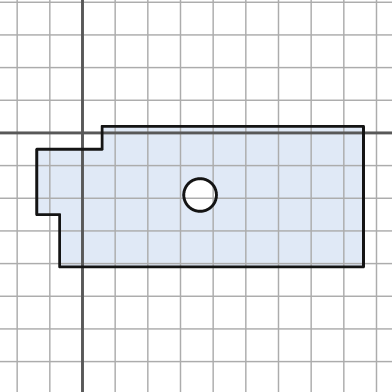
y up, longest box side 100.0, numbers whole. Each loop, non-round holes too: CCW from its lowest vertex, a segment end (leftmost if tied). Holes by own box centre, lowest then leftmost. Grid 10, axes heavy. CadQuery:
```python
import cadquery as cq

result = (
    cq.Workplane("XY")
    .moveTo(-7.0, -41.0)
    .lineTo(86.0, -41.0)
    .lineTo(86.0, 2.0)
    .lineTo(6.0, 2.0)
    .lineTo(6.0, -5.0)
    .lineTo(-14.0, -5.0)
    .lineTo(-14.0, -25.0)
    .lineTo(-7.0, -25.0)
    .close()
    .moveTo(36.0, -19.0)
    .circle(5.0)
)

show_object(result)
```